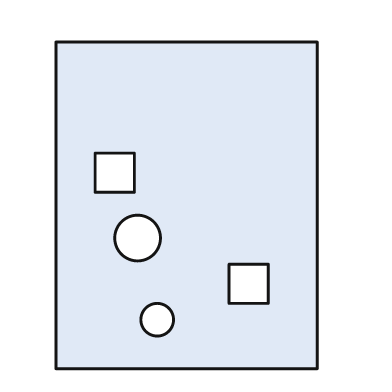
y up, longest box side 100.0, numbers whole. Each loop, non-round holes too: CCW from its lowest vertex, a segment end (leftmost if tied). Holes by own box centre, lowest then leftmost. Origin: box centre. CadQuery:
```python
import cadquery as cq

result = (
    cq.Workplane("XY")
    .moveTo(-40.0, -50.0)
    .lineTo(40.0, -50.0)
    .lineTo(40.0, 50.0)
    .lineTo(-40.0, 50.0)
    .close()
    .moveTo(-9.0, -35.0)
    .circle(5.0)
    .moveTo(13.0, -30.0)
    .lineTo(25.0, -30.0)
    .lineTo(25.0, -18.0)
    .lineTo(13.0, -18.0)
    .close()
    .moveTo(-15.0, -10.0)
    .circle(7.0)
    .moveTo(-28.0, 4.0)
    .lineTo(-16.0, 4.0)
    .lineTo(-16.0, 16.0)
    .lineTo(-28.0, 16.0)
    .close()
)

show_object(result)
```